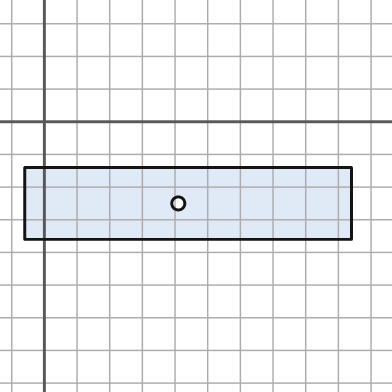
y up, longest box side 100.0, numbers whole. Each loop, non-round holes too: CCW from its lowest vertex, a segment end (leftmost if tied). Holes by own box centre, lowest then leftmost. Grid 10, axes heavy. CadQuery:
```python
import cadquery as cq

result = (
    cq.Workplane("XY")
    .moveTo(-6.0, -36.0)
    .lineTo(94.0, -36.0)
    .lineTo(94.0, -14.0)
    .lineTo(-6.0, -14.0)
    .close()
    .moveTo(41.0, -25.0)
    .circle(2.0)
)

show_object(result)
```